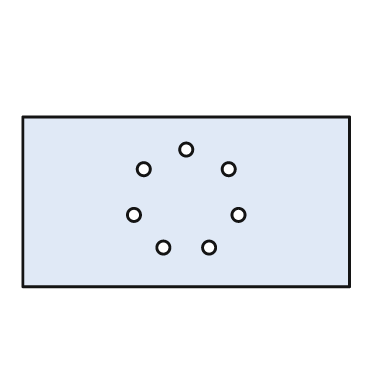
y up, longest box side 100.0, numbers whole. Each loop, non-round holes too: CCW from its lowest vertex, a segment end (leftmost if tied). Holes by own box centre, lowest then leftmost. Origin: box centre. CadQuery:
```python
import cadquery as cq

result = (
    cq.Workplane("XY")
    .moveTo(-50.0, -26.0)
    .lineTo(50.0, -26.0)
    .lineTo(50.0, 26.0)
    .lineTo(-50.0, 26.0)
    .close()
    .moveTo(-7.0, -14.0)
    .circle(2.0)
    .moveTo(7.0, -14.0)
    .circle(2.0)
    .moveTo(-16.0, -4.0)
    .circle(2.0)
    .moveTo(16.0, -4.0)
    .circle(2.0)
    .moveTo(-13.0, 10.0)
    .circle(2.0)
    .moveTo(13.0, 10.0)
    .circle(2.0)
    .moveTo(0.0, 16.0)
    .circle(2.0)
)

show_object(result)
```